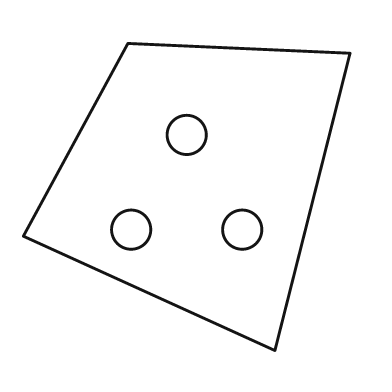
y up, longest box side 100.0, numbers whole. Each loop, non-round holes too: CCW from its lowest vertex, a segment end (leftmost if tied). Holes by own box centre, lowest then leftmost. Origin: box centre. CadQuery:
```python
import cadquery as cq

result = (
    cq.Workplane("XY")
    .moveTo(27.0, -47.0)
    .lineTo(50.0, 44.0)
    .lineTo(-18.0, 47.0)
    .lineTo(-50.0, -12.0)
    .close()
    .moveTo(-17.0, -10.0)
    .circle(6.0)
    .moveTo(17.0, -10.0)
    .circle(6.0)
    .moveTo(0.0, 19.0)
    .circle(6.0)
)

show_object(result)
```